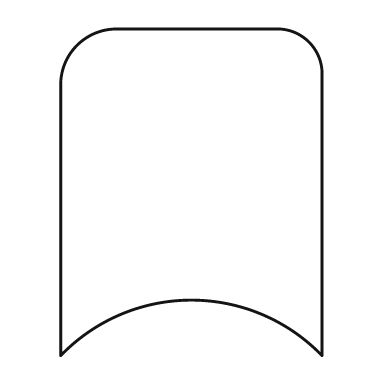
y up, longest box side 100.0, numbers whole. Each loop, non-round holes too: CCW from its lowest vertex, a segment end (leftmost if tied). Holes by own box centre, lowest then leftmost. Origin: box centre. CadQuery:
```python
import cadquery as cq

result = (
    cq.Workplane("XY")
    .moveTo(-40.0, -50.0)
    .threePointArc((0.0, -33.0), (40.0, -50.0))
    .lineTo(40.0, 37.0)
    .threePointArc((36.0, 46.0), (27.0, 50.0))
    .lineTo(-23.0, 50.0)
    .threePointArc((-35.0, 45.0), (-40.0, 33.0))
    .close()
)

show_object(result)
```